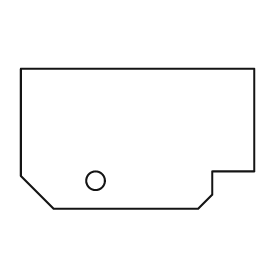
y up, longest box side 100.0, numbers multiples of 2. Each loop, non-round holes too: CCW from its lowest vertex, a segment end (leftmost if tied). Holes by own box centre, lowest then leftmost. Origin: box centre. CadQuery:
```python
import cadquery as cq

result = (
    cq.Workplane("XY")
    .moveTo(-36.0, -30.0)
    .lineTo(26.0, -30.0)
    .lineTo(32.0, -24.0)
    .lineTo(32.0, -14.0)
    .lineTo(50.0, -14.0)
    .lineTo(50.0, 30.0)
    .lineTo(-50.0, 30.0)
    .lineTo(-50.0, -16.0)
    .close()
    .moveTo(-18.0, -18.0)
    .circle(4.0)
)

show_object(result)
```